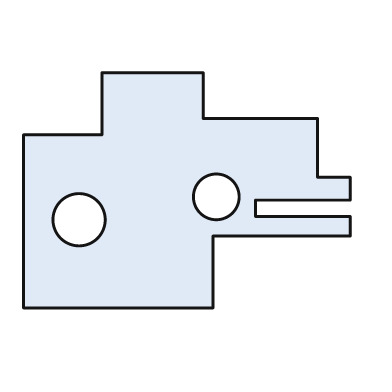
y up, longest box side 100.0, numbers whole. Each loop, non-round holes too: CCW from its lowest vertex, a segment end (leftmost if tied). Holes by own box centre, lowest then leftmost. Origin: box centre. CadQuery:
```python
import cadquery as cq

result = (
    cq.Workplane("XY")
    .moveTo(-50.0, -36.0)
    .lineTo(8.0, -36.0)
    .lineTo(8.0, -14.0)
    .lineTo(50.0, -14.0)
    .lineTo(50.0, -8.0)
    .lineTo(21.0, -8.0)
    .lineTo(21.0, -3.0)
    .lineTo(50.0, -3.0)
    .lineTo(50.0, 4.0)
    .lineTo(40.0, 4.0)
    .lineTo(40.0, 22.0)
    .lineTo(5.0, 22.0)
    .lineTo(5.0, 36.0)
    .lineTo(-26.0, 36.0)
    .lineTo(-26.0, 17.0)
    .lineTo(-50.0, 17.0)
    .close()
    .moveTo(-33.0, -9.0)
    .circle(8.0)
    .moveTo(9.0, -2.0)
    .circle(7.0)
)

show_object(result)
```